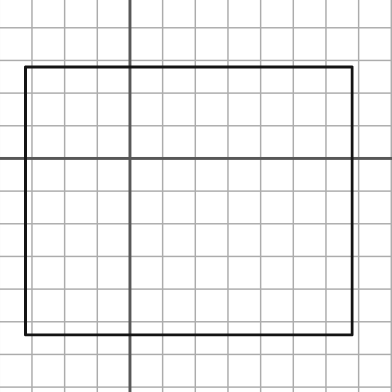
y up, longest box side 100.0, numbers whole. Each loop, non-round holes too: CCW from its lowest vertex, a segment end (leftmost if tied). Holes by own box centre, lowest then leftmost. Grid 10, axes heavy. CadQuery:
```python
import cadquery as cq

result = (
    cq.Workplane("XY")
    .moveTo(-32.0, -54.0)
    .lineTo(68.0, -54.0)
    .lineTo(68.0, 28.0)
    .lineTo(-32.0, 28.0)
    .close()
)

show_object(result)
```